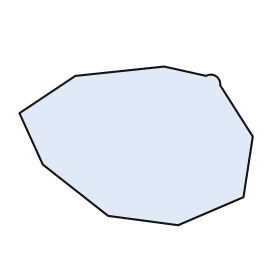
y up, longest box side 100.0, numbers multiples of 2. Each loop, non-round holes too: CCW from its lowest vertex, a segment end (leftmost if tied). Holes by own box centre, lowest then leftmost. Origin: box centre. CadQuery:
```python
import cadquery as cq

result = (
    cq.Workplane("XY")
    .moveTo(18.0, -34.0)
    .lineTo(46.0, -22.0)
    .lineTo(50.0, 4.0)
    .lineTo(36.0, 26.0)
    .threePointArc((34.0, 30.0), (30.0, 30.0))
    .lineTo(12.0, 34.0)
    .lineTo(-26.0, 30.0)
    .lineTo(-50.0, 14.0)
    .lineTo(-40.0, -8.0)
    .lineTo(-12.0, -30.0)
    .close()
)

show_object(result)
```